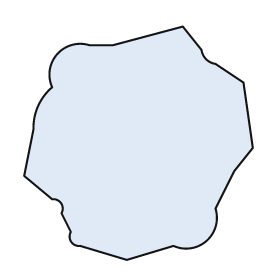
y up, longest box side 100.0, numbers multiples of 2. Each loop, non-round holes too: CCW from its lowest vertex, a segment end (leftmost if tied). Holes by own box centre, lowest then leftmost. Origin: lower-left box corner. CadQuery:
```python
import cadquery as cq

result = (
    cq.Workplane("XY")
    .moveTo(44.0, 0.0)
    .lineTo(64.0, 6.0)
    .threePointArc((78.0, 8.0), (82.0, 22.0))
    .lineTo(90.0, 38.0)
    .lineTo(98.0, 48.0)
    .lineTo(94.0, 76.0)
    .lineTo(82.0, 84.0)
    .threePointArc((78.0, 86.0), (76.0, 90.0))
    .lineTo(68.0, 100.0)
    .lineTo(38.0, 92.0)
    .lineTo(28.0, 92.0)
    .threePointArc((14.0, 88.0), (12.0, 74.0))
    .threePointArc((6.0, 66.0), (4.0, 56.0))
    .lineTo(0.0, 36.0)
    .lineTo(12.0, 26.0)
    .threePointArc((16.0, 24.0), (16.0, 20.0))
    .lineTo(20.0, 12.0)
    .threePointArc((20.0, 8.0), (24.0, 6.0))
    .close()
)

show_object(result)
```